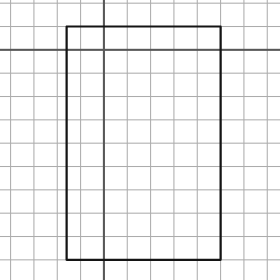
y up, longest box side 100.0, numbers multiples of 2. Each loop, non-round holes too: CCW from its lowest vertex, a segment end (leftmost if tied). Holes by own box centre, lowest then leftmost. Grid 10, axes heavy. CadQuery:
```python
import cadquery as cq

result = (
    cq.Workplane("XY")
    .moveTo(-16.0, -90.0)
    .lineTo(50.0, -90.0)
    .lineTo(50.0, 10.0)
    .lineTo(-16.0, 10.0)
    .close()
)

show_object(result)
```